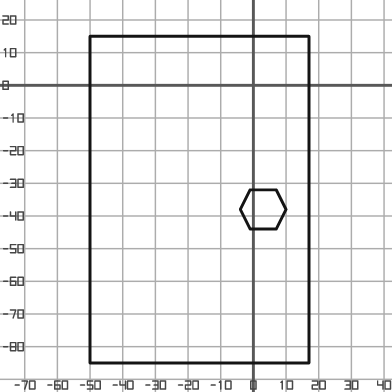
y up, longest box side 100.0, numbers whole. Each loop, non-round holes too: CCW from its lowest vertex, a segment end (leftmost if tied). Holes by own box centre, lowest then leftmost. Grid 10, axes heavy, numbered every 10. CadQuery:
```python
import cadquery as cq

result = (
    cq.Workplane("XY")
    .moveTo(-50.0, -85.0)
    .lineTo(17.0, -85.0)
    .lineTo(17.0, 15.0)
    .lineTo(-50.0, 15.0)
    .close()
    .moveTo(-1.0, -44.0)
    .lineTo(7.0, -44.0)
    .lineTo(10.0, -38.0)
    .lineTo(7.0, -32.0)
    .lineTo(-1.0, -32.0)
    .lineTo(-4.0, -38.0)
    .close()
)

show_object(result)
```